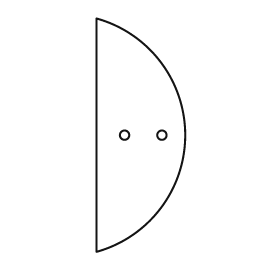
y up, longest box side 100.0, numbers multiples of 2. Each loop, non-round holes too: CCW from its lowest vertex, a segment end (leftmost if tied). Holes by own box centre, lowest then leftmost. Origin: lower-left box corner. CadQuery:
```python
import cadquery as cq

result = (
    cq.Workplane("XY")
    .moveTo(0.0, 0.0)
    .threePointArc((38.0, 50.0), (0.0, 100.0))
    .close()
    .moveTo(12.0, 50.0)
    .circle(2.0)
    .moveTo(28.0, 50.0)
    .circle(2.0)
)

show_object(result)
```